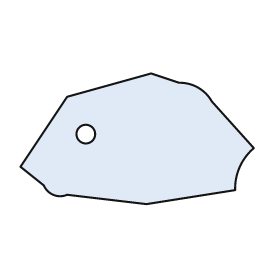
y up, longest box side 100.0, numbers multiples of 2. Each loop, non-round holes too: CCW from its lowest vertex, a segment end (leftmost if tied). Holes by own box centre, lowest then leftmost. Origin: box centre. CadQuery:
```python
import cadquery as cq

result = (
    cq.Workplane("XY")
    .moveTo(4.0, -28.0)
    .lineTo(42.0, -22.0)
    .threePointArc((44.0, -12.0), (50.0, -4.0))
    .lineTo(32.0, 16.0)
    .threePointArc((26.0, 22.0), (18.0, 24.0))
    .lineTo(6.0, 28.0)
    .lineTo(-30.0, 18.0)
    .lineTo(-50.0, -12.0)
    .lineTo(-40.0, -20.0)
    .threePointArc((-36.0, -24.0), (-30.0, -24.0))
    .close()
    .moveTo(-22.0, 2.0)
    .circle(4.0)
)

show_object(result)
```